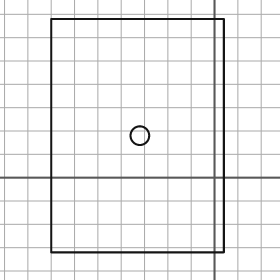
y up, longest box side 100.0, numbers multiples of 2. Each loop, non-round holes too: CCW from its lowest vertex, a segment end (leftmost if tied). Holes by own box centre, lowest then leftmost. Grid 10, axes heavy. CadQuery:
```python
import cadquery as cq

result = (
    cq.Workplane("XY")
    .moveTo(-70.0, -32.0)
    .lineTo(4.0, -32.0)
    .lineTo(4.0, 68.0)
    .lineTo(-70.0, 68.0)
    .close()
    .moveTo(-32.0, 18.0)
    .circle(4.0)
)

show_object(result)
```